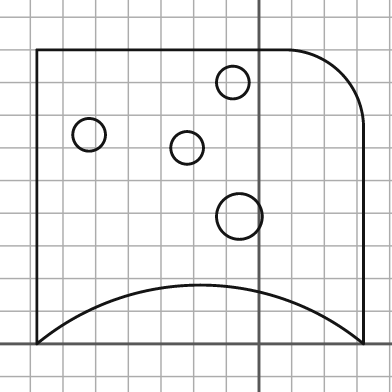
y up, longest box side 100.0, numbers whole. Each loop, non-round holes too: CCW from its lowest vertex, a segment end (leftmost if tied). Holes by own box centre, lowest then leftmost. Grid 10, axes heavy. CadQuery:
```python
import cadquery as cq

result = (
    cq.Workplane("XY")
    .moveTo(-68.0, 0.0)
    .threePointArc((-18.0, 18.0), (32.0, 0.0))
    .lineTo(32.0, 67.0)
    .threePointArc((25.0, 83.0), (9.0, 90.0))
    .lineTo(-68.0, 90.0)
    .close()
    .moveTo(-6.0, 39.0)
    .circle(7.0)
    .moveTo(-22.0, 60.0)
    .circle(5.0)
    .moveTo(-52.0, 64.0)
    .circle(5.0)
    .moveTo(-8.0, 80.0)
    .circle(5.0)
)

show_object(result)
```